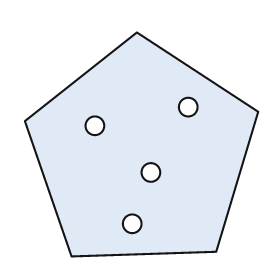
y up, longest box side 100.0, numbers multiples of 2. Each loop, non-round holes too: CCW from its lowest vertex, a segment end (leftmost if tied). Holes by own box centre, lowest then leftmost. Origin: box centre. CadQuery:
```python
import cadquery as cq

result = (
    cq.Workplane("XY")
    .moveTo(-30.0, -48.0)
    .lineTo(32.0, -46.0)
    .lineTo(50.0, 14.0)
    .lineTo(-2.0, 48.0)
    .lineTo(-50.0, 10.0)
    .close()
    .moveTo(-4.0, -34.0)
    .circle(4.0)
    .moveTo(4.0, -12.0)
    .circle(4.0)
    .moveTo(-20.0, 8.0)
    .circle(4.0)
    .moveTo(20.0, 16.0)
    .circle(4.0)
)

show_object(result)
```